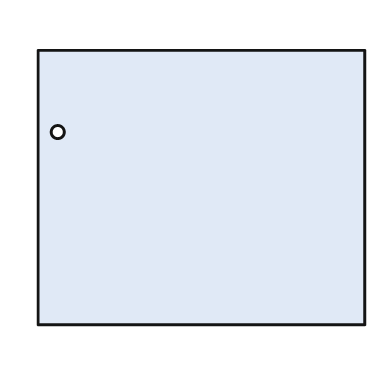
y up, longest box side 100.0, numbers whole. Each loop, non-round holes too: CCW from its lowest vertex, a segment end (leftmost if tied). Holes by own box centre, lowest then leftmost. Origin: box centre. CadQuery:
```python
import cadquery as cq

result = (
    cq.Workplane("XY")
    .moveTo(-50.0, -42.0)
    .lineTo(50.0, -42.0)
    .lineTo(50.0, 42.0)
    .lineTo(-50.0, 42.0)
    .close()
    .moveTo(-44.0, 17.0)
    .circle(2.0)
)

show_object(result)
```